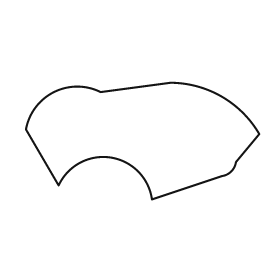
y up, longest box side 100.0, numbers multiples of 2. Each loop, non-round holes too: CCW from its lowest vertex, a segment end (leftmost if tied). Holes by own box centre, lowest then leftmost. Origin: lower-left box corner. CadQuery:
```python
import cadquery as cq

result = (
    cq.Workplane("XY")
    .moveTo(54.0, 0.0)
    .lineTo(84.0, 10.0)
    .threePointArc((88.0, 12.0), (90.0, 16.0))
    .lineTo(100.0, 28.0)
    .threePointArc((84.0, 44.0), (62.0, 50.0))
    .lineTo(32.0, 46.0)
    .threePointArc((12.0, 46.0), (0.0, 30.0))
    .lineTo(14.0, 6.0)
    .threePointArc((36.0, 18.0), (54.0, 0.0))
    .close()
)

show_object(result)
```